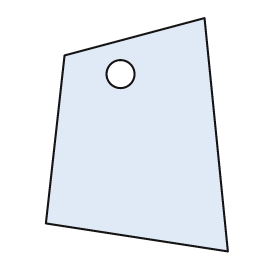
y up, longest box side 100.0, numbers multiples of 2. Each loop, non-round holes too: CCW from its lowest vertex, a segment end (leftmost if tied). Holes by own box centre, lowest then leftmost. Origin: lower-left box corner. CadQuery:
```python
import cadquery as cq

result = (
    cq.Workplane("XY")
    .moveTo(78.0, 0.0)
    .lineTo(68.0, 100.0)
    .lineTo(8.0, 84.0)
    .lineTo(0.0, 12.0)
    .close()
    .moveTo(32.0, 76.0)
    .circle(6.0)
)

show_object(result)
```